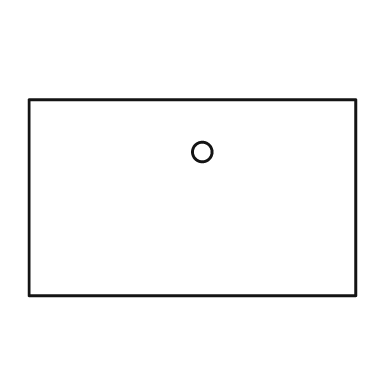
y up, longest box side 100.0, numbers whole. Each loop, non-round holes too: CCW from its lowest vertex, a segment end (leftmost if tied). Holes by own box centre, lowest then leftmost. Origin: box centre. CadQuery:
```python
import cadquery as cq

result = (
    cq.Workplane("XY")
    .moveTo(-50.0, -30.0)
    .lineTo(50.0, -30.0)
    .lineTo(50.0, 30.0)
    .lineTo(-50.0, 30.0)
    .close()
    .moveTo(3.0, 14.0)
    .circle(3.0)
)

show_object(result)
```